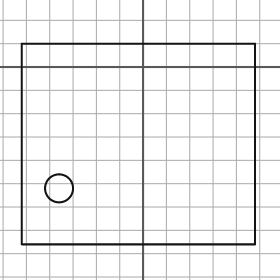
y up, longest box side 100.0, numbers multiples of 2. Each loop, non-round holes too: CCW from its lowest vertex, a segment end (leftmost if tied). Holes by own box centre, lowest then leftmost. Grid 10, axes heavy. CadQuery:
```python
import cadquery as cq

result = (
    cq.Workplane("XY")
    .moveTo(-52.0, -76.0)
    .lineTo(48.0, -76.0)
    .lineTo(48.0, 10.0)
    .lineTo(-52.0, 10.0)
    .close()
    .moveTo(-36.0, -52.0)
    .circle(6.0)
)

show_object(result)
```